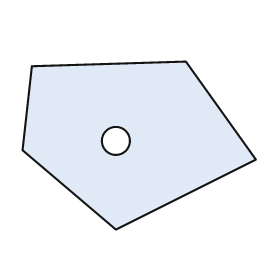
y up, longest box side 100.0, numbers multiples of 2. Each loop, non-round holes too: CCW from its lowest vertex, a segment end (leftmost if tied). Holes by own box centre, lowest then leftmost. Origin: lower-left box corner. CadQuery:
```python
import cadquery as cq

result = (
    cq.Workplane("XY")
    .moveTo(40.0, 0.0)
    .lineTo(100.0, 30.0)
    .lineTo(70.0, 72.0)
    .lineTo(4.0, 70.0)
    .lineTo(0.0, 34.0)
    .close()
    .moveTo(40.0, 38.0)
    .circle(6.0)
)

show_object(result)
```